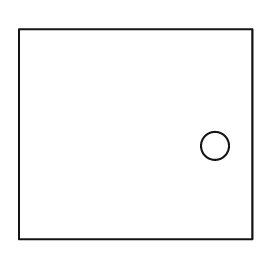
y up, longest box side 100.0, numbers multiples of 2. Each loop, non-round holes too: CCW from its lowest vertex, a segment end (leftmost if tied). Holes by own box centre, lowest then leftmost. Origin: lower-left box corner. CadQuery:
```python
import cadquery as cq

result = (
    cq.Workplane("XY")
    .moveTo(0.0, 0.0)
    .lineTo(100.0, 0.0)
    .lineTo(100.0, 90.0)
    .lineTo(0.0, 90.0)
    .close()
    .moveTo(84.0, 40.0)
    .circle(6.0)
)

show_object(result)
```